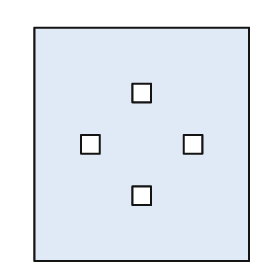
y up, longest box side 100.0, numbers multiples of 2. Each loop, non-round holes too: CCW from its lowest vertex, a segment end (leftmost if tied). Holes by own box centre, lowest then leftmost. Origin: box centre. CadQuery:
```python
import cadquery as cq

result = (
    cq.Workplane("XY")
    .moveTo(-46.0, -50.0)
    .lineTo(46.0, -50.0)
    .lineTo(46.0, 50.0)
    .lineTo(-46.0, 50.0)
    .close()
    .moveTo(-4.0, -26.0)
    .lineTo(4.0, -26.0)
    .lineTo(4.0, -18.0)
    .lineTo(-4.0, -18.0)
    .close()
    .moveTo(-26.0, -4.0)
    .lineTo(-18.0, -4.0)
    .lineTo(-18.0, 4.0)
    .lineTo(-26.0, 4.0)
    .close()
    .moveTo(18.0, -4.0)
    .lineTo(26.0, -4.0)
    .lineTo(26.0, 4.0)
    .lineTo(18.0, 4.0)
    .close()
    .moveTo(-4.0, 18.0)
    .lineTo(4.0, 18.0)
    .lineTo(4.0, 26.0)
    .lineTo(-4.0, 26.0)
    .close()
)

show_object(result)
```